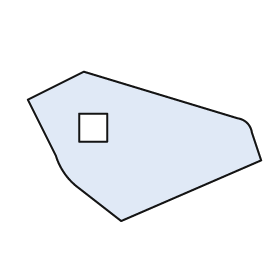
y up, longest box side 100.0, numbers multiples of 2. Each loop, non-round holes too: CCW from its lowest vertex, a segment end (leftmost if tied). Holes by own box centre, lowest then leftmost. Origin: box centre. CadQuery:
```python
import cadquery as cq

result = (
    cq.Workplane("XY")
    .moveTo(-10.0, -32.0)
    .lineTo(50.0, -6.0)
    .lineTo(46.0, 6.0)
    .threePointArc((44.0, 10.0), (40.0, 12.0))
    .lineTo(-26.0, 32.0)
    .lineTo(-50.0, 20.0)
    .lineTo(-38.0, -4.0)
    .threePointArc((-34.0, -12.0), (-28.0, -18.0))
    .close()
    .moveTo(-28.0, 2.0)
    .lineTo(-16.0, 2.0)
    .lineTo(-16.0, 14.0)
    .lineTo(-28.0, 14.0)
    .close()
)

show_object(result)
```